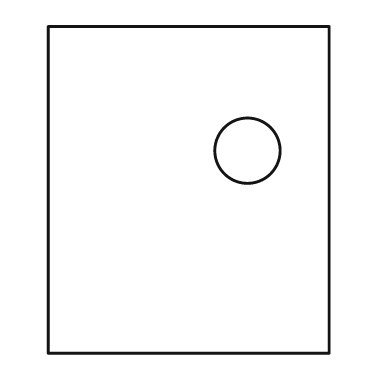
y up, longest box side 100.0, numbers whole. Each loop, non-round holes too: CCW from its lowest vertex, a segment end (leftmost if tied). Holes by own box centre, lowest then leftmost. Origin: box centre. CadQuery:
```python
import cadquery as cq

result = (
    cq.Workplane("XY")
    .moveTo(-43.0, -50.0)
    .lineTo(43.0, -50.0)
    .lineTo(43.0, 50.0)
    .lineTo(-43.0, 50.0)
    .close()
    .moveTo(18.0, 12.0)
    .circle(10.0)
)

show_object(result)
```